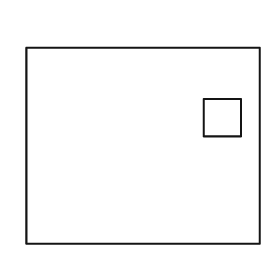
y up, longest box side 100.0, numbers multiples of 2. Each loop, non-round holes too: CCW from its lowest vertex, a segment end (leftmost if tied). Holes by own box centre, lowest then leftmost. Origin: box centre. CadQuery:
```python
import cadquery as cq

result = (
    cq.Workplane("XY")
    .moveTo(-50.0, -42.0)
    .lineTo(50.0, -42.0)
    .lineTo(50.0, 42.0)
    .lineTo(-50.0, 42.0)
    .close()
    .moveTo(26.0, 4.0)
    .lineTo(42.0, 4.0)
    .lineTo(42.0, 20.0)
    .lineTo(26.0, 20.0)
    .close()
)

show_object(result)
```